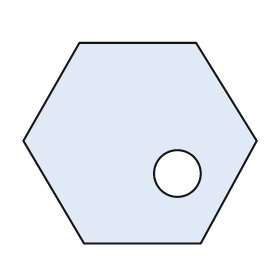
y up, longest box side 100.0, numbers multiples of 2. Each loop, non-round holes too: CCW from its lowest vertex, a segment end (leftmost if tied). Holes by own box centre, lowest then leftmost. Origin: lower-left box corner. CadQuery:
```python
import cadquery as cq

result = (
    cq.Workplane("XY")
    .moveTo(26.0, 0.0)
    .lineTo(76.0, 0.0)
    .lineTo(100.0, 44.0)
    .lineTo(74.0, 86.0)
    .lineTo(24.0, 86.0)
    .lineTo(0.0, 44.0)
    .close()
    .moveTo(66.0, 30.0)
    .circle(10.0)
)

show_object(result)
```